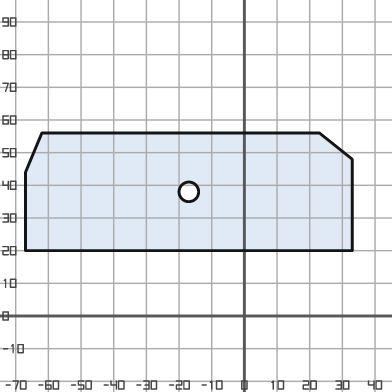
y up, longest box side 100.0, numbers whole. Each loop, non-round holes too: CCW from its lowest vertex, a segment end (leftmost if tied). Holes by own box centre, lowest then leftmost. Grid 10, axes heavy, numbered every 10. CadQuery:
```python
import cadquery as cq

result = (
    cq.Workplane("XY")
    .moveTo(-67.0, 20.0)
    .lineTo(33.0, 20.0)
    .lineTo(33.0, 48.0)
    .lineTo(23.0, 56.0)
    .lineTo(-62.0, 56.0)
    .lineTo(-67.0, 44.0)
    .close()
    .moveTo(-17.0, 38.0)
    .circle(3.0)
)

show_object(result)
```